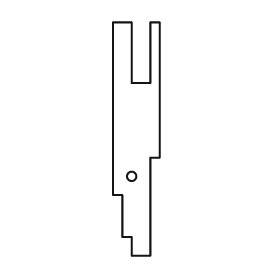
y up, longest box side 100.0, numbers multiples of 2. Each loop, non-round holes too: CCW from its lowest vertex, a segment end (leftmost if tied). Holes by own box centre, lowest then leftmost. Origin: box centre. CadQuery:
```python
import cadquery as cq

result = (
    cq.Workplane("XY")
    .moveTo(-2.0, -50.0)
    .lineTo(6.0, -50.0)
    .lineTo(6.0, -8.0)
    .lineTo(10.0, -8.0)
    .lineTo(10.0, 50.0)
    .lineTo(6.0, 50.0)
    .lineTo(6.0, 24.0)
    .lineTo(-2.0, 24.0)
    .lineTo(-2.0, 50.0)
    .lineTo(-10.0, 50.0)
    .lineTo(-10.0, -24.0)
    .lineTo(-6.0, -24.0)
    .lineTo(-6.0, -42.0)
    .lineTo(-2.0, -42.0)
    .close()
    .moveTo(-2.0, -16.0)
    .circle(2.0)
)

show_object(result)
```